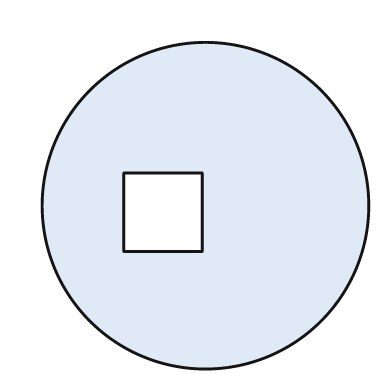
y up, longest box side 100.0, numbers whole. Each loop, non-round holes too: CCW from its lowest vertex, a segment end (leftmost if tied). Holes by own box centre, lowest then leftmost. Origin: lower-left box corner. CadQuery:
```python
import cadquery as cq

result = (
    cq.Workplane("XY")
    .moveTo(50.0, 50.0)
    .circle(50.0)
    .moveTo(25.0, 36.0)
    .lineTo(49.0, 36.0)
    .lineTo(49.0, 60.0)
    .lineTo(25.0, 60.0)
    .close()
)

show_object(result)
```